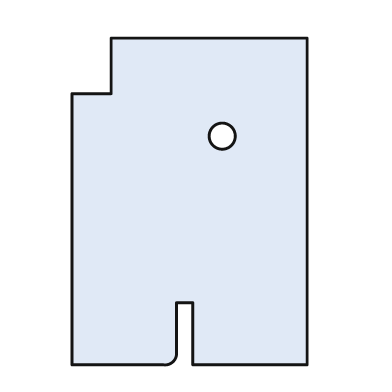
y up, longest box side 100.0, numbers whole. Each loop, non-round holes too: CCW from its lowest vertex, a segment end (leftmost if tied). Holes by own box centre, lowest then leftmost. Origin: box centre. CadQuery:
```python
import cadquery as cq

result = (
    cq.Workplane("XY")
    .moveTo(-36.0, -50.0)
    .lineTo(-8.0, -50.0)
    .threePointArc((-5.0, -49.0), (-4.0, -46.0))
    .lineTo(-4.0, -31.0)
    .lineTo(1.0, -31.0)
    .lineTo(1.0, -50.0)
    .lineTo(36.0, -50.0)
    .lineTo(36.0, 50.0)
    .lineTo(-24.0, 50.0)
    .lineTo(-24.0, 33.0)
    .lineTo(-36.0, 33.0)
    .close()
    .moveTo(10.0, 20.0)
    .circle(4.0)
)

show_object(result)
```